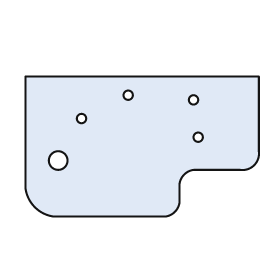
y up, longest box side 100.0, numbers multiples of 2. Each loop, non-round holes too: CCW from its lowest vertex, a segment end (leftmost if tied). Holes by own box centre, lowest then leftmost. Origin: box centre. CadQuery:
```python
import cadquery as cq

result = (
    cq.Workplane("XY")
    .moveTo(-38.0, -30.0)
    .lineTo(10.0, -30.0)
    .threePointArc((14.0, -28.0), (16.0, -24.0))
    .lineTo(16.0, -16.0)
    .threePointArc((18.0, -12.0), (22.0, -10.0))
    .lineTo(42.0, -10.0)
    .threePointArc((48.0, -8.0), (50.0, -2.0))
    .lineTo(50.0, 30.0)
    .lineTo(-50.0, 30.0)
    .lineTo(-50.0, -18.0)
    .threePointArc((-46.0, -26.0), (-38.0, -30.0))
    .close()
    .moveTo(-36.0, -6.0)
    .circle(4.0)
    .moveTo(24.0, 4.0)
    .circle(2.0)
    .moveTo(-26.0, 12.0)
    .circle(2.0)
    .moveTo(22.0, 20.0)
    .circle(2.0)
    .moveTo(-6.0, 22.0)
    .circle(2.0)
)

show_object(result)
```